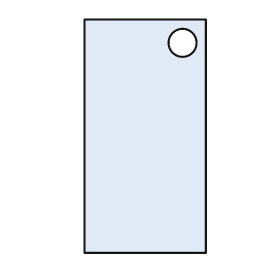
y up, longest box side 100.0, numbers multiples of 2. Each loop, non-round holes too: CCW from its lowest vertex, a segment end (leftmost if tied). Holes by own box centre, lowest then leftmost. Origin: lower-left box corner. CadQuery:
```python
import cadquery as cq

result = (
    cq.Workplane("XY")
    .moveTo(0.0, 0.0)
    .lineTo(52.0, 0.0)
    .lineTo(52.0, 100.0)
    .lineTo(0.0, 100.0)
    .close()
    .moveTo(42.0, 90.0)
    .circle(6.0)
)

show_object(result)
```